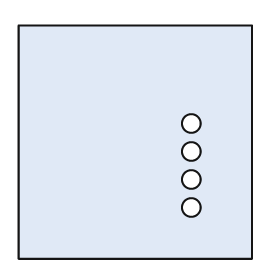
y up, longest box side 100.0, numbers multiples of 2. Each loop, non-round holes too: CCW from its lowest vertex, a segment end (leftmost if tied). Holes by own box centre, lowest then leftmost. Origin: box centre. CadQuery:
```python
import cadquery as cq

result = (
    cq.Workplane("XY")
    .moveTo(-50.0, -50.0)
    .lineTo(50.0, -50.0)
    .lineTo(50.0, 50.0)
    .lineTo(-50.0, 50.0)
    .close()
    .moveTo(24.0, -28.0)
    .circle(4.0)
    .moveTo(24.0, -16.0)
    .circle(4.0)
    .moveTo(24.0, -4.0)
    .circle(4.0)
    .moveTo(24.0, 8.0)
    .circle(4.0)
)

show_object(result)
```